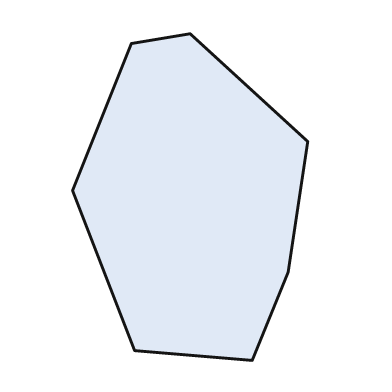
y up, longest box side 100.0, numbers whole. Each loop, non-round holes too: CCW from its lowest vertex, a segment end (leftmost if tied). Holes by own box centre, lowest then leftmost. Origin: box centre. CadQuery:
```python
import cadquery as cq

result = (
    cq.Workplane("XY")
    .moveTo(19.0, -50.0)
    .lineTo(30.0, -23.0)
    .lineTo(36.0, 17.0)
    .lineTo(0.0, 50.0)
    .lineTo(-18.0, 47.0)
    .lineTo(-36.0, 2.0)
    .lineTo(-17.0, -47.0)
    .close()
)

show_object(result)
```